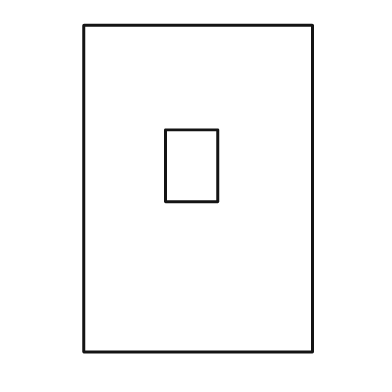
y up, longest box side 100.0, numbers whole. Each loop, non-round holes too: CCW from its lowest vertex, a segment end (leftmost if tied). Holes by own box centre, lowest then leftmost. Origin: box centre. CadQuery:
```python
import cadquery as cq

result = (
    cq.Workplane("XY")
    .moveTo(-35.0, -50.0)
    .lineTo(35.0, -50.0)
    .lineTo(35.0, 50.0)
    .lineTo(-35.0, 50.0)
    .close()
    .moveTo(-10.0, -4.0)
    .lineTo(6.0, -4.0)
    .lineTo(6.0, 18.0)
    .lineTo(-10.0, 18.0)
    .close()
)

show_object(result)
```